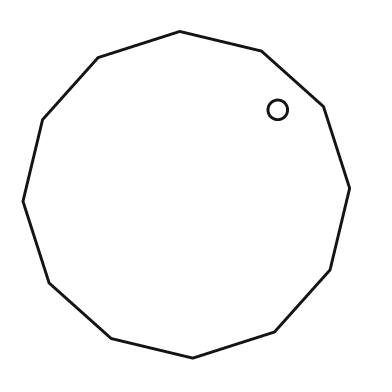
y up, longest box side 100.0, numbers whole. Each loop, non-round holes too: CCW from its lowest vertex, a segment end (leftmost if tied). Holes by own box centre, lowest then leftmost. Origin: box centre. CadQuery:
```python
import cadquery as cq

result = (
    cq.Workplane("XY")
    .moveTo(2.0, -50.0)
    .lineTo(27.0, -42.0)
    .lineTo(44.0, -23.0)
    .lineTo(50.0, 2.0)
    .lineTo(42.0, 27.0)
    .lineTo(23.0, 44.0)
    .lineTo(-2.0, 50.0)
    .lineTo(-27.0, 42.0)
    .lineTo(-44.0, 23.0)
    .lineTo(-50.0, -2.0)
    .lineTo(-42.0, -27.0)
    .lineTo(-23.0, -44.0)
    .close()
    .moveTo(28.0, 26.0)
    .circle(3.0)
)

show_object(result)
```